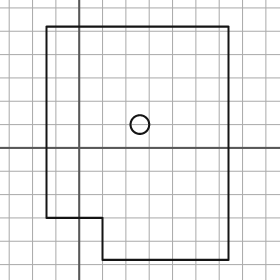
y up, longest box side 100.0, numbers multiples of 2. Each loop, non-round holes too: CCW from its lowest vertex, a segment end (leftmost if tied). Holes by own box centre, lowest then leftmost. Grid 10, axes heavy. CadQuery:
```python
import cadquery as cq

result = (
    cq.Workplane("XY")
    .moveTo(10.0, -48.0)
    .lineTo(64.0, -48.0)
    .lineTo(64.0, 52.0)
    .lineTo(-14.0, 52.0)
    .lineTo(-14.0, -30.0)
    .lineTo(10.0, -30.0)
    .close()
    .moveTo(26.0, 10.0)
    .circle(4.0)
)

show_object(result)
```